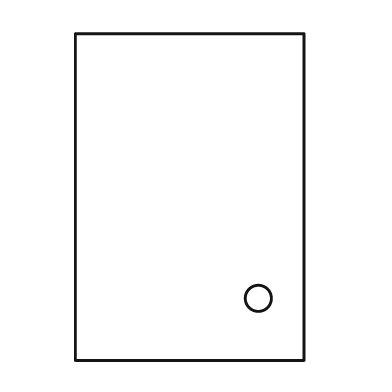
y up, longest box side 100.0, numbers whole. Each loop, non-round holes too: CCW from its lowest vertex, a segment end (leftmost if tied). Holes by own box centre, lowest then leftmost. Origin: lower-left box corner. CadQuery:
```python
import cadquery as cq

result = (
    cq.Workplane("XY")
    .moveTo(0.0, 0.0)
    .lineTo(70.0, 0.0)
    .lineTo(70.0, 100.0)
    .lineTo(0.0, 100.0)
    .close()
    .moveTo(56.0, 19.0)
    .circle(4.0)
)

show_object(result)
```